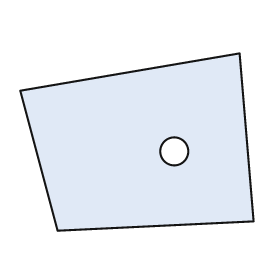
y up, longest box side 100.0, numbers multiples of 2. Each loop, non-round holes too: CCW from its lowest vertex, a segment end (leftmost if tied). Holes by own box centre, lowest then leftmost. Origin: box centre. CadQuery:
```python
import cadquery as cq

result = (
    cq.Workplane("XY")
    .moveTo(-34.0, -38.0)
    .lineTo(50.0, -34.0)
    .lineTo(44.0, 38.0)
    .lineTo(-50.0, 22.0)
    .close()
    .moveTo(16.0, -4.0)
    .circle(6.0)
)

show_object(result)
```